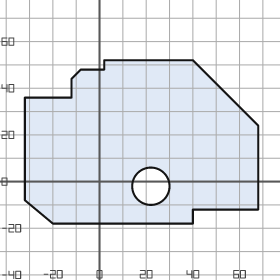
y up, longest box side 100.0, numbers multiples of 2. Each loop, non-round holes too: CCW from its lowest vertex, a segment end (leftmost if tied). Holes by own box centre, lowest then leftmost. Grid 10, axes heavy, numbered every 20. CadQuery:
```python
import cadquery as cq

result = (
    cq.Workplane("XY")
    .moveTo(-20.0, -18.0)
    .lineTo(40.0, -18.0)
    .lineTo(40.0, -12.0)
    .lineTo(68.0, -12.0)
    .lineTo(68.0, 24.0)
    .lineTo(40.0, 52.0)
    .lineTo(2.0, 52.0)
    .lineTo(2.0, 48.0)
    .lineTo(-8.0, 48.0)
    .lineTo(-12.0, 44.0)
    .lineTo(-12.0, 36.0)
    .lineTo(-32.0, 36.0)
    .lineTo(-32.0, -8.0)
    .close()
    .moveTo(22.0, -2.0)
    .circle(8.0)
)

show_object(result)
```